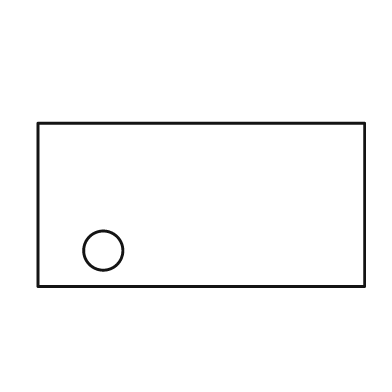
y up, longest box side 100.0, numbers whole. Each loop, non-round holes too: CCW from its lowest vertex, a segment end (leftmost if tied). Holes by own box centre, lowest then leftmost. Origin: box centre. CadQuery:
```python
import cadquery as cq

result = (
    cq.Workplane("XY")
    .moveTo(-50.0, -25.0)
    .lineTo(50.0, -25.0)
    .lineTo(50.0, 25.0)
    .lineTo(-50.0, 25.0)
    .close()
    .moveTo(-30.0, -14.0)
    .circle(6.0)
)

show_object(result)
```